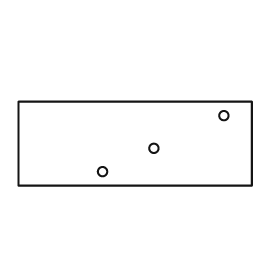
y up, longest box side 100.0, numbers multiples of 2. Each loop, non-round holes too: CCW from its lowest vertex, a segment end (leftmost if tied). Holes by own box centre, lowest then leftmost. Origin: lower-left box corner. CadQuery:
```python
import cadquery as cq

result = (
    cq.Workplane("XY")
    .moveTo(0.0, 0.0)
    .lineTo(100.0, 0.0)
    .lineTo(100.0, 36.0)
    .lineTo(0.0, 36.0)
    .close()
    .moveTo(36.0, 6.0)
    .circle(2.0)
    .moveTo(58.0, 16.0)
    .circle(2.0)
    .moveTo(88.0, 30.0)
    .circle(2.0)
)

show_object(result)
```